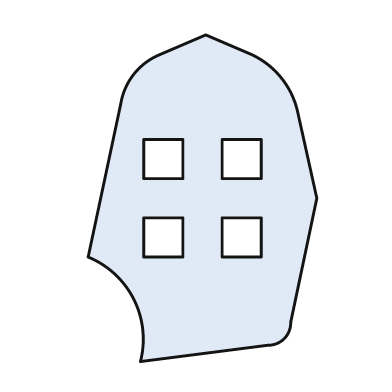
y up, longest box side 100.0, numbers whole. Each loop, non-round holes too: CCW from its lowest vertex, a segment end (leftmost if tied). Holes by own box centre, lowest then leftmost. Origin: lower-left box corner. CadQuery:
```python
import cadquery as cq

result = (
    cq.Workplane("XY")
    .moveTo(16.0, 0.0)
    .lineTo(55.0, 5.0)
    .threePointArc((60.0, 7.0), (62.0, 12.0))
    .lineTo(70.0, 50.0)
    .lineTo(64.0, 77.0)
    .threePointArc((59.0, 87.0), (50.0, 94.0))
    .lineTo(36.0, 100.0)
    .lineTo(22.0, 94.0)
    .threePointArc((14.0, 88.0), (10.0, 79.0))
    .lineTo(0.0, 32.0)
    .threePointArc((14.0, 19.0), (16.0, 0.0))
    .close()
    .moveTo(17.0, 32.0)
    .lineTo(29.0, 32.0)
    .lineTo(29.0, 44.0)
    .lineTo(17.0, 44.0)
    .close()
    .moveTo(41.0, 32.0)
    .lineTo(53.0, 32.0)
    .lineTo(53.0, 44.0)
    .lineTo(41.0, 44.0)
    .close()
    .moveTo(17.0, 56.0)
    .lineTo(29.0, 56.0)
    .lineTo(29.0, 68.0)
    .lineTo(17.0, 68.0)
    .close()
    .moveTo(41.0, 56.0)
    .lineTo(53.0, 56.0)
    .lineTo(53.0, 68.0)
    .lineTo(41.0, 68.0)
    .close()
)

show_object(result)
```